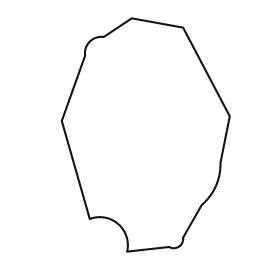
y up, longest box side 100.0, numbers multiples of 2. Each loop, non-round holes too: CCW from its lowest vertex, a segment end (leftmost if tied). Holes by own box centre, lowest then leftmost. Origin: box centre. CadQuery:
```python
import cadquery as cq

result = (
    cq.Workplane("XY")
    .moveTo(-8.0, -50.0)
    .lineTo(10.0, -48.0)
    .threePointArc((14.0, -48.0), (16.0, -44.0))
    .lineTo(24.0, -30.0)
    .threePointArc((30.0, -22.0), (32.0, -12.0))
    .lineTo(36.0, 8.0)
    .lineTo(16.0, 46.0)
    .lineTo(-6.0, 50.0)
    .lineTo(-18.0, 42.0)
    .threePointArc((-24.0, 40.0), (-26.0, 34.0))
    .lineTo(-36.0, 6.0)
    .lineTo(-24.0, -36.0)
    .threePointArc((-12.0, -38.0), (-8.0, -50.0))
    .close()
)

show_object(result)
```